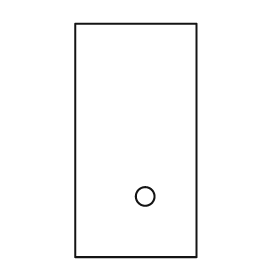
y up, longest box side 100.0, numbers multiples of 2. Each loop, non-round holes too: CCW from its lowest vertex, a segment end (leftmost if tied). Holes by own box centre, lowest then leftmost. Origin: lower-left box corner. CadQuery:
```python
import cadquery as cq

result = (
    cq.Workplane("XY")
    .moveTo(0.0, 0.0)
    .lineTo(52.0, 0.0)
    .lineTo(52.0, 100.0)
    .lineTo(0.0, 100.0)
    .close()
    .moveTo(30.0, 26.0)
    .circle(4.0)
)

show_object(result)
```